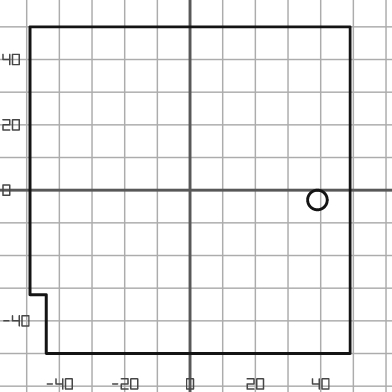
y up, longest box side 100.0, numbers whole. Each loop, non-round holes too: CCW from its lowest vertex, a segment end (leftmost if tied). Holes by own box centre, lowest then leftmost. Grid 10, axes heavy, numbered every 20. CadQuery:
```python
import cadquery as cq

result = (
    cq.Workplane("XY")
    .moveTo(-44.0, -50.0)
    .lineTo(49.0, -50.0)
    .lineTo(49.0, 50.0)
    .lineTo(-49.0, 50.0)
    .lineTo(-49.0, -32.0)
    .lineTo(-44.0, -32.0)
    .close()
    .moveTo(39.0, -3.0)
    .circle(3.0)
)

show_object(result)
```